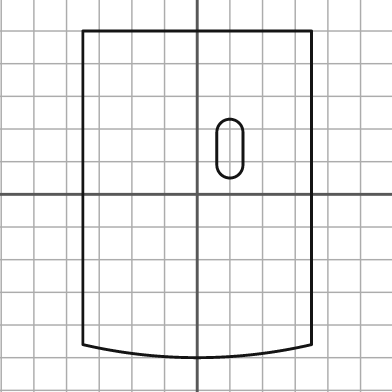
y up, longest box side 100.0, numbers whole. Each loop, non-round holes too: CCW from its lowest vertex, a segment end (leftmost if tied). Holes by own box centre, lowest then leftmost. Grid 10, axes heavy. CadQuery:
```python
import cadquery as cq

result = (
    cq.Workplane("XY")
    .moveTo(-35.0, -46.0)
    .threePointArc((0.0, -50.0), (35.0, -46.0))
    .lineTo(35.0, 50.0)
    .lineTo(-35.0, 50.0)
    .close()
    .moveTo(6.0, 9.0)
    .threePointArc((10.0, 5.0), (14.0, 9.0))
    .lineTo(14.0, 19.0)
    .threePointArc((10.0, 23.0), (6.0, 19.0))
    .close()
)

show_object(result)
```